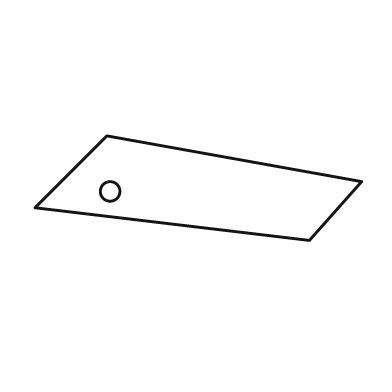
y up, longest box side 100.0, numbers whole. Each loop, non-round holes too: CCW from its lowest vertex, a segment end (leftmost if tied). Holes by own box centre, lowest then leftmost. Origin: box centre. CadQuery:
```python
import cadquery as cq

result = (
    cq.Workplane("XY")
    .moveTo(34.0, -16.0)
    .lineTo(50.0, 2.0)
    .lineTo(-28.0, 16.0)
    .lineTo(-50.0, -6.0)
    .close()
    .moveTo(-27.0, -1.0)
    .circle(3.0)
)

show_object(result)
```